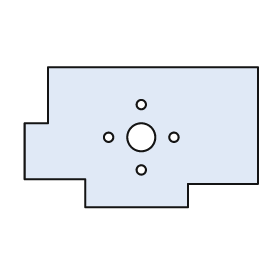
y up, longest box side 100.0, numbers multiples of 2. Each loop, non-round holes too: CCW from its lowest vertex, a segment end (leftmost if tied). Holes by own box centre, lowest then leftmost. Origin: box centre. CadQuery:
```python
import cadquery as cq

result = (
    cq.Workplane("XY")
    .moveTo(-24.0, -30.0)
    .lineTo(20.0, -30.0)
    .lineTo(20.0, -20.0)
    .lineTo(50.0, -20.0)
    .lineTo(50.0, 30.0)
    .lineTo(-40.0, 30.0)
    .lineTo(-40.0, 6.0)
    .lineTo(-50.0, 6.0)
    .lineTo(-50.0, -18.0)
    .lineTo(-24.0, -18.0)
    .close()
    .moveTo(0.0, -14.0)
    .circle(2.0)
    .moveTo(-14.0, 0.0)
    .circle(2.0)
    .moveTo(0.0, 0.0)
    .circle(6.0)
    .moveTo(14.0, 0.0)
    .circle(2.0)
    .moveTo(0.0, 14.0)
    .circle(2.0)
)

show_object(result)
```